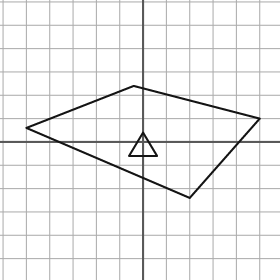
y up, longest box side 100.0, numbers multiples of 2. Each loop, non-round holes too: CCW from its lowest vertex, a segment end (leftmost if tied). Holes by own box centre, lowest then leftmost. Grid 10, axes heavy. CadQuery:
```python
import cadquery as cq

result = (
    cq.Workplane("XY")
    .moveTo(20.0, -24.0)
    .lineTo(50.0, 10.0)
    .lineTo(-4.0, 24.0)
    .lineTo(-50.0, 6.0)
    .close()
    .moveTo(-6.0, -6.0)
    .lineTo(6.0, -6.0)
    .lineTo(0.0, 4.0)
    .close()
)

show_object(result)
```